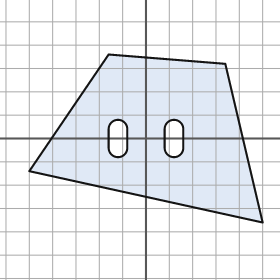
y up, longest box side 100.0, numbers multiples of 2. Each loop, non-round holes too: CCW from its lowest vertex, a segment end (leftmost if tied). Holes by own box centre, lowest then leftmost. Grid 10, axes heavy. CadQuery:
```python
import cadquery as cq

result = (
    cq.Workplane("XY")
    .moveTo(50.0, -36.0)
    .lineTo(34.0, 32.0)
    .lineTo(-16.0, 36.0)
    .lineTo(-50.0, -14.0)
    .close()
    .moveTo(-16.0, -4.0)
    .threePointArc((-12.0, -8.0), (-8.0, -4.0))
    .lineTo(-8.0, 4.0)
    .threePointArc((-12.0, 8.0), (-16.0, 4.0))
    .close()
    .moveTo(8.0, -4.0)
    .threePointArc((12.0, -8.0), (16.0, -4.0))
    .lineTo(16.0, 4.0)
    .threePointArc((12.0, 8.0), (8.0, 4.0))
    .close()
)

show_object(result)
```